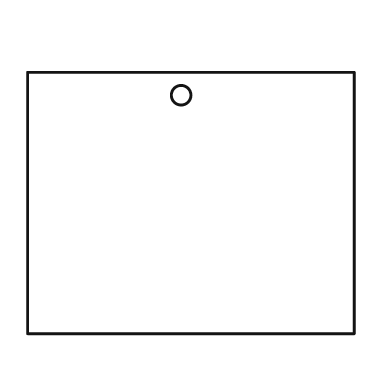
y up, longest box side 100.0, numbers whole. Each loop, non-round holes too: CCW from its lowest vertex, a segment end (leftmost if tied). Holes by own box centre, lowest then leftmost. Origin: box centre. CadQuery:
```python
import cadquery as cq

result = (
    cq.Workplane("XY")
    .moveTo(-50.0, -40.0)
    .lineTo(50.0, -40.0)
    .lineTo(50.0, 40.0)
    .lineTo(-50.0, 40.0)
    .close()
    .moveTo(-3.0, 33.0)
    .circle(3.0)
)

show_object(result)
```